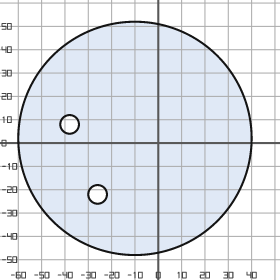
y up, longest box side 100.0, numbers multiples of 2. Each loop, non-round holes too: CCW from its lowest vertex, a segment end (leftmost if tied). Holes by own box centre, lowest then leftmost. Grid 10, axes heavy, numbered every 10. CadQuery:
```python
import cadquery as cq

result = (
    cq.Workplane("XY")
    .moveTo(-10.0, 2.0)
    .circle(50.0)
    .moveTo(-26.0, -22.0)
    .circle(4.0)
    .moveTo(-38.0, 8.0)
    .circle(4.0)
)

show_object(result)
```